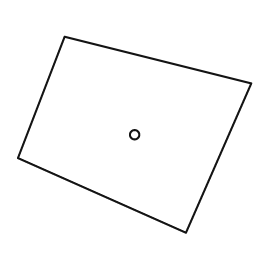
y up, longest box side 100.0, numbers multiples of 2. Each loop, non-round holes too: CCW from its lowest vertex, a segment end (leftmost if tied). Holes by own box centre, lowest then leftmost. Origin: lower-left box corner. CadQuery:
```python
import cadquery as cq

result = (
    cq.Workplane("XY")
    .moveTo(72.0, 0.0)
    .lineTo(100.0, 64.0)
    .lineTo(20.0, 84.0)
    .lineTo(0.0, 32.0)
    .close()
    .moveTo(50.0, 42.0)
    .circle(2.0)
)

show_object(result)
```